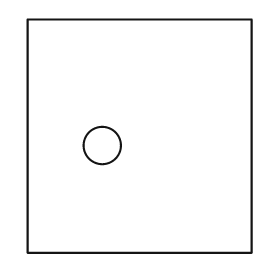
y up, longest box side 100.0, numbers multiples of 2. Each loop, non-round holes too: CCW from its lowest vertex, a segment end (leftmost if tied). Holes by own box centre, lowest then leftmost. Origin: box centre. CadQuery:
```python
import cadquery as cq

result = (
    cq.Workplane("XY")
    .moveTo(-48.0, -50.0)
    .lineTo(48.0, -50.0)
    .lineTo(48.0, 50.0)
    .lineTo(-48.0, 50.0)
    .close()
    .moveTo(-16.0, -4.0)
    .circle(8.0)
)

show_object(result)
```